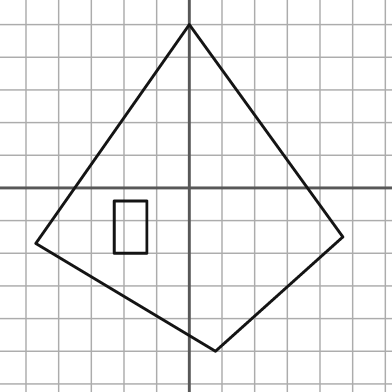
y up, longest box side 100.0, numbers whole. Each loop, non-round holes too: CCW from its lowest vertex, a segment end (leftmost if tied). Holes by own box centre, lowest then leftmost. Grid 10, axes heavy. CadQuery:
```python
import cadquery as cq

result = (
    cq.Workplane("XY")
    .moveTo(8.0, -50.0)
    .lineTo(47.0, -15.0)
    .lineTo(0.0, 50.0)
    .lineTo(-47.0, -17.0)
    .close()
    .moveTo(-23.0, -20.0)
    .lineTo(-13.0, -20.0)
    .lineTo(-13.0, -4.0)
    .lineTo(-23.0, -4.0)
    .close()
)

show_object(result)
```